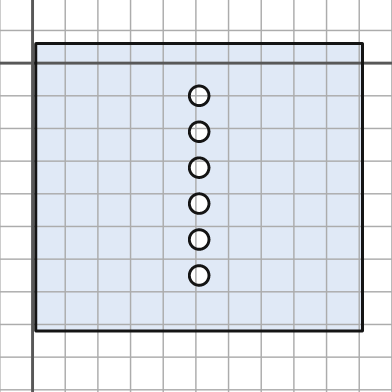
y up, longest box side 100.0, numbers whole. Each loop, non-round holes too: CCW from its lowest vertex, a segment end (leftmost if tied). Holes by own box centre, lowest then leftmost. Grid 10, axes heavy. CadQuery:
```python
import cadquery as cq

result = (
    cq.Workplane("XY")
    .moveTo(1.0, -82.0)
    .lineTo(101.0, -82.0)
    .lineTo(101.0, 6.0)
    .lineTo(1.0, 6.0)
    .close()
    .moveTo(51.0, -65.0)
    .circle(3.0)
    .moveTo(51.0, -54.0)
    .circle(3.0)
    .moveTo(51.0, -43.0)
    .circle(3.0)
    .moveTo(51.0, -32.0)
    .circle(3.0)
    .moveTo(51.0, -21.0)
    .circle(3.0)
    .moveTo(51.0, -10.0)
    .circle(3.0)
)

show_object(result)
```